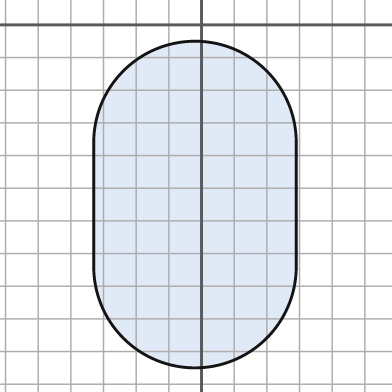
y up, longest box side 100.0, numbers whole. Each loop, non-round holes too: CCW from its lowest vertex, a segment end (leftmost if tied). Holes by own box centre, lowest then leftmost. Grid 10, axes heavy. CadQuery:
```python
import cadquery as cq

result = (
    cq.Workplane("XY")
    .moveTo(-33.0, -74.0)
    .threePointArc((-2.0, -105.0), (29.0, -74.0))
    .lineTo(29.0, -36.0)
    .threePointArc((-2.0, -5.0), (-33.0, -36.0))
    .close()
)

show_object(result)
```